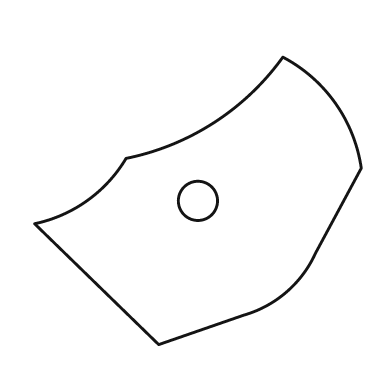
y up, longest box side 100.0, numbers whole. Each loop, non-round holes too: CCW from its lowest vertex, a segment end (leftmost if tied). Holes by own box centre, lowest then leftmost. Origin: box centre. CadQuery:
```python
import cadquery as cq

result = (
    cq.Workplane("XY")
    .moveTo(-12.0, -44.0)
    .lineTo(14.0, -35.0)
    .threePointArc((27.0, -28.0), (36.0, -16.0))
    .lineTo(50.0, 10.0)
    .threePointArc((42.0, 30.0), (26.0, 44.0))
    .threePointArc((5.0, 24.0), (-22.0, 13.0))
    .threePointArc((-34.0, 0.0), (-50.0, -7.0))
    .close()
    .moveTo(0.0, 0.0)
    .circle(6.0)
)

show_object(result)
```